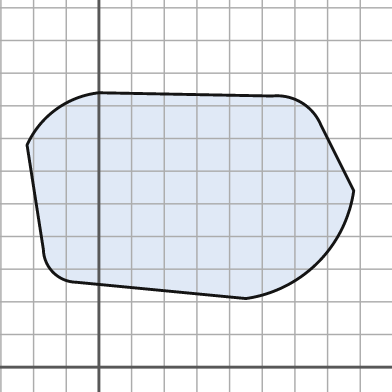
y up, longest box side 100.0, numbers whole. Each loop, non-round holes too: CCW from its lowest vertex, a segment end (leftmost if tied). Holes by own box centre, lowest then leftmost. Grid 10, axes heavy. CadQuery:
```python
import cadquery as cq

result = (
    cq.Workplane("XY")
    .moveTo(45.0, 21.0)
    .threePointArc((67.0, 32.0), (78.0, 54.0))
    .lineTo(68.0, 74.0)
    .threePointArc((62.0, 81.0), (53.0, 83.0))
    .lineTo(0.0, 84.0)
    .threePointArc((-13.0, 79.0), (-22.0, 68.0))
    .lineTo(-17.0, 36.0)
    .threePointArc((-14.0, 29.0), (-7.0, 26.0))
    .close()
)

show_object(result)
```